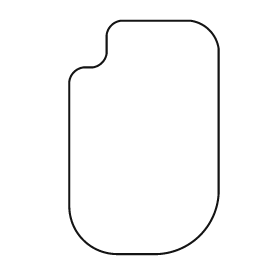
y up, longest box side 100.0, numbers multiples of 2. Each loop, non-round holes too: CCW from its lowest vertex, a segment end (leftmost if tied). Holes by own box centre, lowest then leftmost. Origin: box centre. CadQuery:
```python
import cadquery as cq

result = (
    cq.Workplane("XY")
    .moveTo(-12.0, -50.0)
    .lineTo(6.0, -50.0)
    .threePointArc((24.0, -42.0), (32.0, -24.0))
    .lineTo(32.0, 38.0)
    .threePointArc((28.0, 46.0), (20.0, 50.0))
    .lineTo(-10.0, 50.0)
    .threePointArc((-14.0, 48.0), (-16.0, 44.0))
    .lineTo(-16.0, 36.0)
    .threePointArc((-18.0, 32.0), (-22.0, 30.0))
    .lineTo(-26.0, 30.0)
    .threePointArc((-30.0, 28.0), (-32.0, 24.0))
    .lineTo(-32.0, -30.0)
    .threePointArc((-26.0, -44.0), (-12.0, -50.0))
    .close()
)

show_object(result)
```